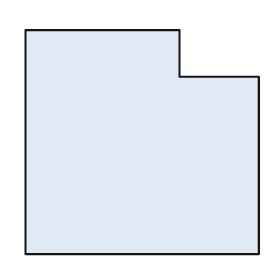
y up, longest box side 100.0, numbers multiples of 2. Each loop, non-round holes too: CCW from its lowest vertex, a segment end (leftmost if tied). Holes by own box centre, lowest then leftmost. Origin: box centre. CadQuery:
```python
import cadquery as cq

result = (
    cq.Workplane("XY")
    .moveTo(-50.0, -48.0)
    .lineTo(50.0, -48.0)
    .lineTo(50.0, 28.0)
    .lineTo(16.0, 28.0)
    .lineTo(16.0, 48.0)
    .lineTo(-50.0, 48.0)
    .close()
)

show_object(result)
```